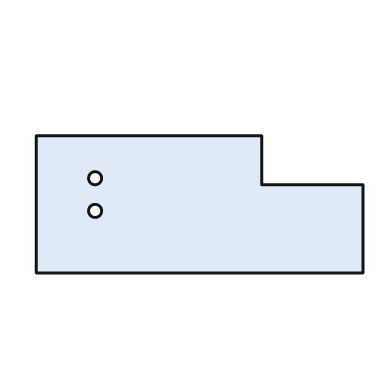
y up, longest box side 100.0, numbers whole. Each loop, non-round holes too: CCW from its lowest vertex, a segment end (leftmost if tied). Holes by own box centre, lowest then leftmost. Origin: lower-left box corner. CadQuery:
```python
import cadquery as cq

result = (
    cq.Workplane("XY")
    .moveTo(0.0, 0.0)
    .lineTo(100.0, 0.0)
    .lineTo(100.0, 27.0)
    .lineTo(69.0, 27.0)
    .lineTo(69.0, 42.0)
    .lineTo(0.0, 42.0)
    .close()
    .moveTo(18.0, 19.0)
    .circle(2.0)
    .moveTo(18.0, 29.0)
    .circle(2.0)
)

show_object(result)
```